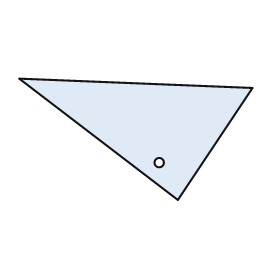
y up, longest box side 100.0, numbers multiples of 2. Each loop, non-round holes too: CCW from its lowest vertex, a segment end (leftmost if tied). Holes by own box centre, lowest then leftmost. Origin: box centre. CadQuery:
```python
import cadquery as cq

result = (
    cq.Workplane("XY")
    .moveTo(18.0, -26.0)
    .lineTo(50.0, 22.0)
    .lineTo(-50.0, 26.0)
    .close()
    .moveTo(10.0, -10.0)
    .circle(2.0)
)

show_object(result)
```